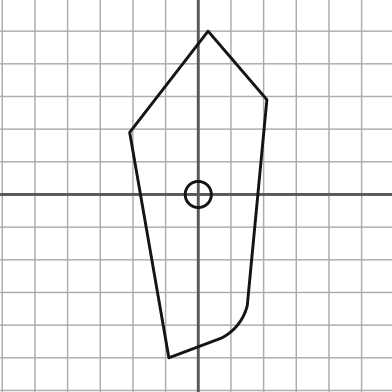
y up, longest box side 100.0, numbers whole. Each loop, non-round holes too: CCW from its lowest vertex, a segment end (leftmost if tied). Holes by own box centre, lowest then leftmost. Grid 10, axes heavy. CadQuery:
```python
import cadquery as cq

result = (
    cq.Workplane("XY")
    .moveTo(-9.0, -50.0)
    .lineTo(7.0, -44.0)
    .threePointArc((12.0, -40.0), (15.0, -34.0))
    .lineTo(21.0, 29.0)
    .lineTo(3.0, 50.0)
    .lineTo(-21.0, 19.0)
    .close()
    .moveTo(0.0, 0.0)
    .circle(4.0)
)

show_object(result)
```